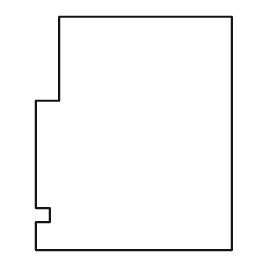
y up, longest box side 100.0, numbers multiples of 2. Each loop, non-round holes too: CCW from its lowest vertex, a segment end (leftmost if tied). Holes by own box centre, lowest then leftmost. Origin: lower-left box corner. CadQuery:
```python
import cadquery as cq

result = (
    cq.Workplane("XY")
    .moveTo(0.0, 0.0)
    .lineTo(84.0, 0.0)
    .lineTo(84.0, 100.0)
    .lineTo(10.0, 100.0)
    .lineTo(10.0, 64.0)
    .lineTo(0.0, 64.0)
    .lineTo(0.0, 18.0)
    .lineTo(6.0, 18.0)
    .lineTo(6.0, 12.0)
    .lineTo(0.0, 12.0)
    .close()
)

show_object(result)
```